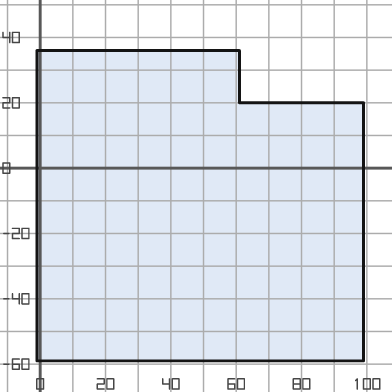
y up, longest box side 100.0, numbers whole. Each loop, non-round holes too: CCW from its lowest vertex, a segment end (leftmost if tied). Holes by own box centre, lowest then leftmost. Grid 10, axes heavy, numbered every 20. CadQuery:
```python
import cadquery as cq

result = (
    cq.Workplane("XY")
    .moveTo(-1.0, -59.0)
    .lineTo(99.0, -59.0)
    .lineTo(99.0, 20.0)
    .lineTo(61.0, 20.0)
    .lineTo(61.0, 36.0)
    .lineTo(-1.0, 36.0)
    .close()
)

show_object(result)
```